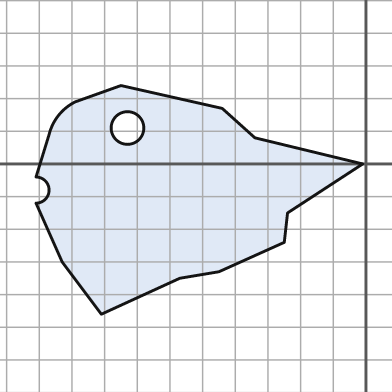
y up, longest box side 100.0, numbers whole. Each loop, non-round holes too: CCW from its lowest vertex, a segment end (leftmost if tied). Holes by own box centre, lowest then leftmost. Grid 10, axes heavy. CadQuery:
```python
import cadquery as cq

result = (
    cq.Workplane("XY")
    .moveTo(-81.0, -46.0)
    .lineTo(-57.0, -35.0)
    .lineTo(-45.0, -33.0)
    .lineTo(-25.0, -24.0)
    .lineTo(-24.0, -15.0)
    .lineTo(-1.0, 0.0)
    .lineTo(-34.0, 8.0)
    .lineTo(-44.0, 17.0)
    .lineTo(-75.0, 24.0)
    .lineTo(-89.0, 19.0)
    .threePointArc((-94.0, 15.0), (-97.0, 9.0))
    .lineTo(-101.0, -4.0)
    .threePointArc((-97.0, -8.0), (-101.0, -12.0))
    .lineTo(-93.0, -30.0)
    .close()
    .moveTo(-73.0, 11.0)
    .circle(5.0)
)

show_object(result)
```